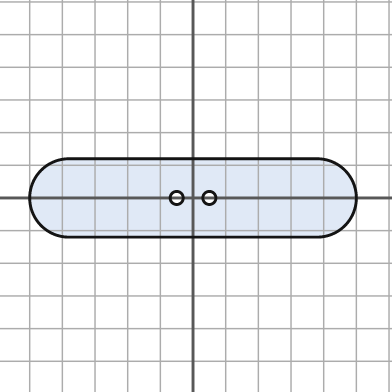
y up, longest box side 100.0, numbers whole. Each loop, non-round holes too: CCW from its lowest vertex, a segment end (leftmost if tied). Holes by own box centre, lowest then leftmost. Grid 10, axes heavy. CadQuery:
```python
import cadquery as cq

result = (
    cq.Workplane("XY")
    .moveTo(-38.0, -12.0)
    .lineTo(38.0, -12.0)
    .threePointArc((50.0, 0.0), (38.0, 12.0))
    .lineTo(-38.0, 12.0)
    .threePointArc((-50.0, 0.0), (-38.0, -12.0))
    .close()
    .moveTo(-5.0, 0.0)
    .circle(2.0)
    .moveTo(5.0, 0.0)
    .circle(2.0)
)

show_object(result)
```